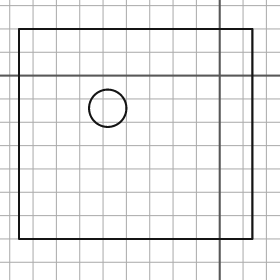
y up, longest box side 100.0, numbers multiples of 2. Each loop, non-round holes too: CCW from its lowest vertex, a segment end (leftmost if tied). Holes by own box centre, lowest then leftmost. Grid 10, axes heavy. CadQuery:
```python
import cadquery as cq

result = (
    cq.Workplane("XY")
    .moveTo(-86.0, -70.0)
    .lineTo(14.0, -70.0)
    .lineTo(14.0, 20.0)
    .lineTo(-86.0, 20.0)
    .close()
    .moveTo(-48.0, -14.0)
    .circle(8.0)
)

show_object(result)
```